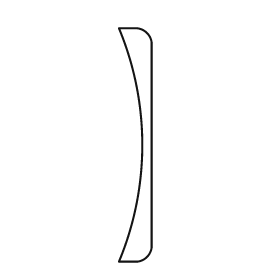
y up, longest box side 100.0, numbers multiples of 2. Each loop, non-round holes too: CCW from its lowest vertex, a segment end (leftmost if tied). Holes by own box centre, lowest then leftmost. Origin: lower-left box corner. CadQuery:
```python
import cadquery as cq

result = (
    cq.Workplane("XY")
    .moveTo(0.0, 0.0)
    .lineTo(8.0, 0.0)
    .threePointArc((12.0, 2.0), (14.0, 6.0))
    .lineTo(14.0, 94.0)
    .threePointArc((12.0, 98.0), (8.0, 100.0))
    .lineTo(0.0, 100.0)
    .threePointArc((10.0, 50.0), (0.0, 0.0))
    .close()
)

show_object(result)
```